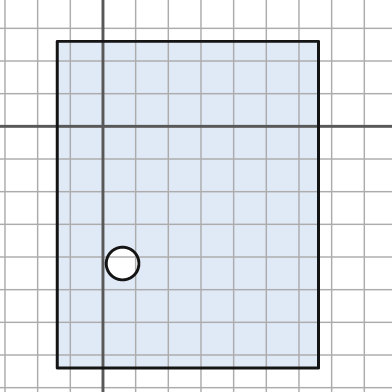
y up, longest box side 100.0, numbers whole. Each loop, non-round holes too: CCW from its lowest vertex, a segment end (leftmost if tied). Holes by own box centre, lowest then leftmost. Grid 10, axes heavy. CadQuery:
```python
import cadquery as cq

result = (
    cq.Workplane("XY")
    .moveTo(-14.0, -74.0)
    .lineTo(66.0, -74.0)
    .lineTo(66.0, 26.0)
    .lineTo(-14.0, 26.0)
    .close()
    .moveTo(6.0, -42.0)
    .circle(5.0)
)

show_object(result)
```